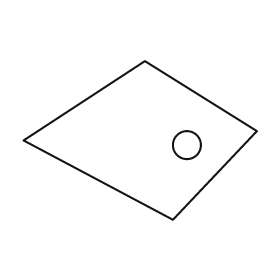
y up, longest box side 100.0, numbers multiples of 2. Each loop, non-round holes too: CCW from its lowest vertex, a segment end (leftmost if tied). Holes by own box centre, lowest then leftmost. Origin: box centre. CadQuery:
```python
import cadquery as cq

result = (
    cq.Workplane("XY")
    .moveTo(14.0, -34.0)
    .lineTo(50.0, 4.0)
    .lineTo(2.0, 34.0)
    .lineTo(-50.0, 0.0)
    .close()
    .moveTo(20.0, -2.0)
    .circle(6.0)
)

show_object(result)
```